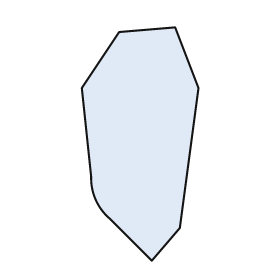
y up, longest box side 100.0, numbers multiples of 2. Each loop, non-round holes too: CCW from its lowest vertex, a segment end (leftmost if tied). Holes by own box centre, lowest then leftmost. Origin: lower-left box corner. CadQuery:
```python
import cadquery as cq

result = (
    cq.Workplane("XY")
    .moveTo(30.0, 0.0)
    .lineTo(42.0, 14.0)
    .lineTo(50.0, 74.0)
    .lineTo(40.0, 100.0)
    .lineTo(16.0, 98.0)
    .lineTo(0.0, 74.0)
    .lineTo(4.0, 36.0)
    .threePointArc((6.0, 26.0), (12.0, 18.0))
    .close()
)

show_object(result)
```